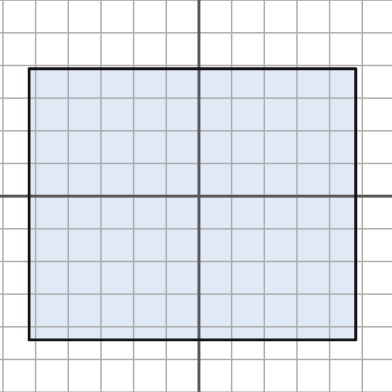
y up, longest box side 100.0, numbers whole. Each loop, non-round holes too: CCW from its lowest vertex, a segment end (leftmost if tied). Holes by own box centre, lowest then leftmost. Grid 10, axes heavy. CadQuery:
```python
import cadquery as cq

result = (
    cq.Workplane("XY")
    .moveTo(-52.0, -44.0)
    .lineTo(48.0, -44.0)
    .lineTo(48.0, 39.0)
    .lineTo(-52.0, 39.0)
    .close()
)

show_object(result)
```